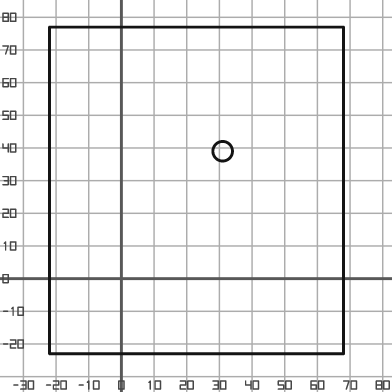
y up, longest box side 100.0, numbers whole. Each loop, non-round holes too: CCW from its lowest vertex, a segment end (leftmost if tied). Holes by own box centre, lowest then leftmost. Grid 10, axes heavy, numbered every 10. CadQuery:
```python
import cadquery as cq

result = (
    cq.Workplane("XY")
    .moveTo(-22.0, -23.0)
    .lineTo(68.0, -23.0)
    .lineTo(68.0, 77.0)
    .lineTo(-22.0, 77.0)
    .close()
    .moveTo(31.0, 39.0)
    .circle(3.0)
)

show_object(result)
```